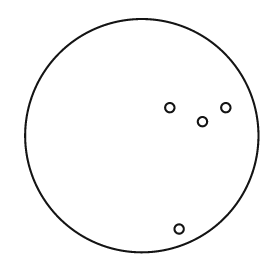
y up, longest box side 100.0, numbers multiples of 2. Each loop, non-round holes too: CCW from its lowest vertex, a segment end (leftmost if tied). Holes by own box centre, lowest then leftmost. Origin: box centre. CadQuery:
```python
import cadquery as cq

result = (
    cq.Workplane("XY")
    .moveTo(0.0, 0.0)
    .circle(50.0)
    .moveTo(16.0, -40.0)
    .circle(2.0)
    .moveTo(26.0, 6.0)
    .circle(2.0)
    .moveTo(12.0, 12.0)
    .circle(2.0)
    .moveTo(36.0, 12.0)
    .circle(2.0)
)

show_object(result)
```